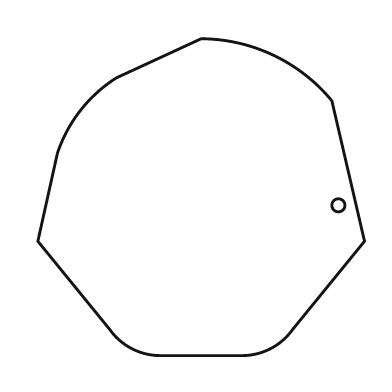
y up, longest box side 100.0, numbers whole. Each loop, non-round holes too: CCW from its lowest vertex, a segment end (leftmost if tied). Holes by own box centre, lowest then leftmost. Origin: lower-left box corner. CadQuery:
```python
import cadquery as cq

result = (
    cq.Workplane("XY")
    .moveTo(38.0, 0.0)
    .lineTo(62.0, 0.0)
    .threePointArc((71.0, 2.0), (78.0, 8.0))
    .lineTo(100.0, 35.0)
    .lineTo(90.0, 78.0)
    .threePointArc((72.0, 92.0), (50.0, 97.0))
    .lineTo(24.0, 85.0)
    .threePointArc((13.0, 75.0), (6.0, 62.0))
    .lineTo(0.0, 35.0)
    .lineTo(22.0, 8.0)
    .threePointArc((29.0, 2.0), (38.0, 0.0))
    .close()
    .moveTo(92.0, 46.0)
    .circle(2.0)
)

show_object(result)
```